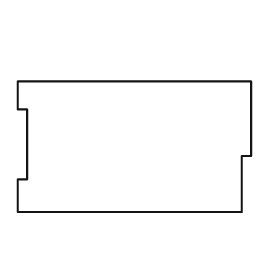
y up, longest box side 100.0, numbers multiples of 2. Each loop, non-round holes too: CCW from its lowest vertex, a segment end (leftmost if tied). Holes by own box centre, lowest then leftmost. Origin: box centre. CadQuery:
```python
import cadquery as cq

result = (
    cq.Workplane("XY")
    .moveTo(-50.0, -28.0)
    .lineTo(46.0, -28.0)
    .lineTo(46.0, -4.0)
    .lineTo(50.0, -4.0)
    .lineTo(50.0, 28.0)
    .lineTo(-50.0, 28.0)
    .lineTo(-50.0, 16.0)
    .lineTo(-46.0, 16.0)
    .lineTo(-46.0, -14.0)
    .lineTo(-50.0, -14.0)
    .close()
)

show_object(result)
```